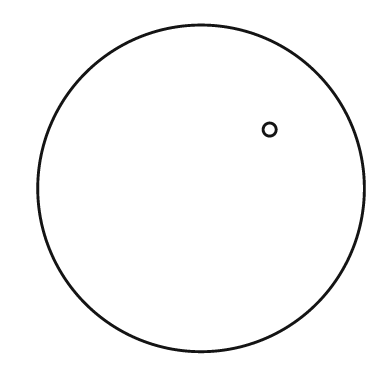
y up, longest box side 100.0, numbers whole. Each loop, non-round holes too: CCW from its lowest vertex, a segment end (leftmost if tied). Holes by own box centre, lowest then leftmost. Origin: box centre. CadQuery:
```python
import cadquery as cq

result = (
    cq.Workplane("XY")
    .moveTo(0.0, 0.0)
    .circle(50.0)
    .moveTo(21.0, 18.0)
    .circle(2.0)
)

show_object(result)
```